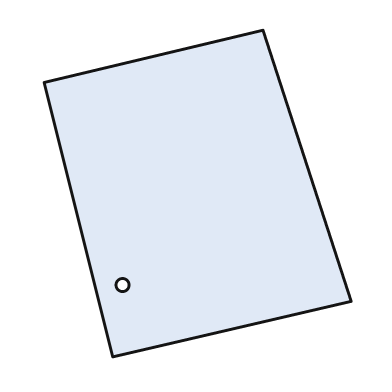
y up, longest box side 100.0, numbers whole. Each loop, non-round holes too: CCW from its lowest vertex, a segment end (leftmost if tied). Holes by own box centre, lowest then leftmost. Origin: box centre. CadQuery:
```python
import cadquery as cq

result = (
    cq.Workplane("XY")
    .moveTo(-26.0, -50.0)
    .lineTo(47.0, -33.0)
    .lineTo(20.0, 50.0)
    .lineTo(-47.0, 34.0)
    .close()
    .moveTo(-23.0, -28.0)
    .circle(2.0)
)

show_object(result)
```